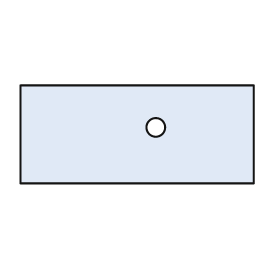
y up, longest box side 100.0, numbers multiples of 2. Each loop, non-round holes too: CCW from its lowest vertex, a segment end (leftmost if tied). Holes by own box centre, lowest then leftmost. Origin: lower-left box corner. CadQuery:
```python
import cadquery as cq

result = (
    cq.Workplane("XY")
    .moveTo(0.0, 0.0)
    .lineTo(100.0, 0.0)
    .lineTo(100.0, 42.0)
    .lineTo(0.0, 42.0)
    .close()
    .moveTo(58.0, 24.0)
    .circle(4.0)
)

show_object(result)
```